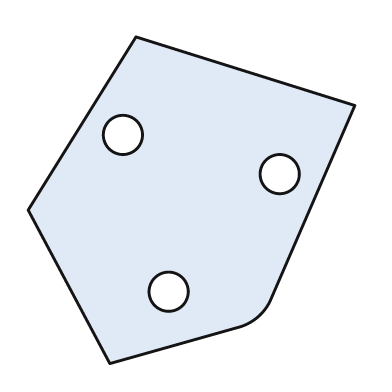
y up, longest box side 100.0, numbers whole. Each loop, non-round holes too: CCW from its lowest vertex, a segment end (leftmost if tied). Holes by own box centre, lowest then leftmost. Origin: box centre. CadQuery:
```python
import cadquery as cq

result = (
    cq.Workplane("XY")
    .moveTo(-25.0, -50.0)
    .lineTo(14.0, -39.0)
    .threePointArc((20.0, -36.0), (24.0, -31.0))
    .lineTo(50.0, 29.0)
    .lineTo(-17.0, 50.0)
    .lineTo(-50.0, -3.0)
    .close()
    .moveTo(-7.0, -28.0)
    .circle(6.0)
    .moveTo(27.0, 8.0)
    .circle(6.0)
    .moveTo(-21.0, 20.0)
    .circle(6.0)
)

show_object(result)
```